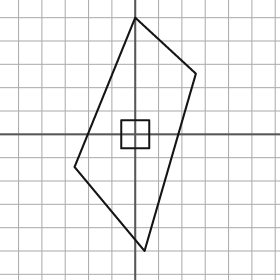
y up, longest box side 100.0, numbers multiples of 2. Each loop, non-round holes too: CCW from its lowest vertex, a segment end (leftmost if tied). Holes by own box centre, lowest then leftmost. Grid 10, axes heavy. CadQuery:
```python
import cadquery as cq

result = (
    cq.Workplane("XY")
    .moveTo(4.0, -50.0)
    .lineTo(26.0, 26.0)
    .lineTo(0.0, 50.0)
    .lineTo(-26.0, -14.0)
    .close()
    .moveTo(-6.0, -6.0)
    .lineTo(6.0, -6.0)
    .lineTo(6.0, 6.0)
    .lineTo(-6.0, 6.0)
    .close()
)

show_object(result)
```